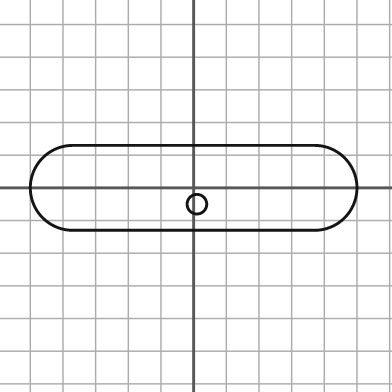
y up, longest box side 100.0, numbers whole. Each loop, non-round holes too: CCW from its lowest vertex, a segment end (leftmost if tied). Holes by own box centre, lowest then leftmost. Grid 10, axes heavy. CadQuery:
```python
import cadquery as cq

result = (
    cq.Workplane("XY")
    .moveTo(-37.0, -13.0)
    .lineTo(37.0, -13.0)
    .threePointArc((50.0, 0.0), (37.0, 13.0))
    .lineTo(-37.0, 13.0)
    .threePointArc((-50.0, 0.0), (-37.0, -13.0))
    .close()
    .moveTo(1.0, -5.0)
    .circle(3.0)
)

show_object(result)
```